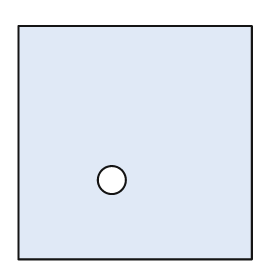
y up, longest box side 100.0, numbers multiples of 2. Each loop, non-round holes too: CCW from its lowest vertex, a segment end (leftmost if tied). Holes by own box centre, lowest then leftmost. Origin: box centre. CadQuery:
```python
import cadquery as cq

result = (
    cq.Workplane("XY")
    .moveTo(-50.0, -50.0)
    .lineTo(50.0, -50.0)
    .lineTo(50.0, 50.0)
    .lineTo(-50.0, 50.0)
    .close()
    .moveTo(-10.0, -16.0)
    .circle(6.0)
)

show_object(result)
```